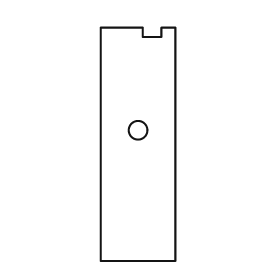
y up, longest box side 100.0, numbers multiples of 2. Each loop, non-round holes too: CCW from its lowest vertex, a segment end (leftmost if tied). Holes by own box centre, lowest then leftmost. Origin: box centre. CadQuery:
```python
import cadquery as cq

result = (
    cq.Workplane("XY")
    .moveTo(-16.0, -50.0)
    .lineTo(16.0, -50.0)
    .lineTo(16.0, 50.0)
    .lineTo(10.0, 50.0)
    .lineTo(10.0, 46.0)
    .lineTo(2.0, 46.0)
    .lineTo(2.0, 50.0)
    .lineTo(-16.0, 50.0)
    .close()
    .moveTo(0.0, 6.0)
    .circle(4.0)
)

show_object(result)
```